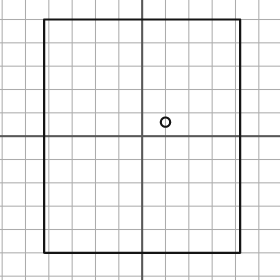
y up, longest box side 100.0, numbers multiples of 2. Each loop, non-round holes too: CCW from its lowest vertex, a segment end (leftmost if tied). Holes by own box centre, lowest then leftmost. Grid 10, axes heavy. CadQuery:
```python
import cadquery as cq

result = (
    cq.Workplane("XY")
    .moveTo(-42.0, -50.0)
    .lineTo(42.0, -50.0)
    .lineTo(42.0, 50.0)
    .lineTo(-42.0, 50.0)
    .close()
    .moveTo(10.0, 6.0)
    .circle(2.0)
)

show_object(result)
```